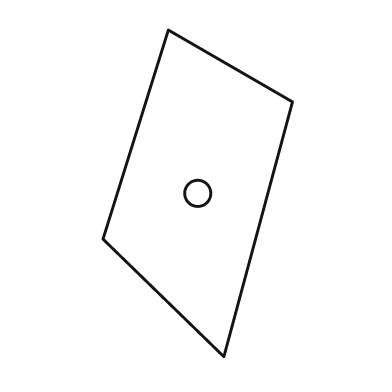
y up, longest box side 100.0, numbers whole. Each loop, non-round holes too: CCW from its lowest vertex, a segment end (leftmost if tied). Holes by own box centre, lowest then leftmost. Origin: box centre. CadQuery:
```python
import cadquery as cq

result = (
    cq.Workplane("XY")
    .moveTo(8.0, -50.0)
    .lineTo(29.0, 28.0)
    .lineTo(-9.0, 50.0)
    .lineTo(-29.0, -14.0)
    .close()
    .moveTo(0.0, 0.0)
    .circle(4.0)
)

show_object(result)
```